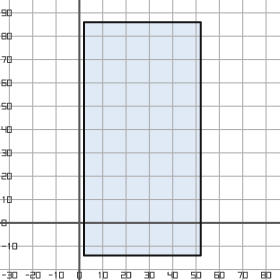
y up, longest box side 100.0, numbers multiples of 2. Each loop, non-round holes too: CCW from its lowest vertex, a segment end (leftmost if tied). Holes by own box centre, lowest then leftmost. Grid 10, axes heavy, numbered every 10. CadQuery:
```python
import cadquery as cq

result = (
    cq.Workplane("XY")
    .moveTo(2.0, -14.0)
    .lineTo(52.0, -14.0)
    .lineTo(52.0, 86.0)
    .lineTo(2.0, 86.0)
    .close()
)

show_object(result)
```